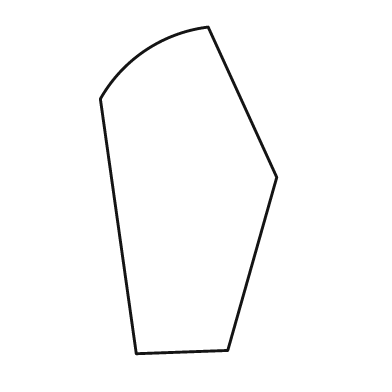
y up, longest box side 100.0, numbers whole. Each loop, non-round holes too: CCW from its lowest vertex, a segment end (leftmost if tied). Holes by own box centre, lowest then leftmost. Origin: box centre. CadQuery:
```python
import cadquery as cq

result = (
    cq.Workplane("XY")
    .moveTo(-16.0, -50.0)
    .lineTo(12.0, -49.0)
    .lineTo(27.0, 4.0)
    .lineTo(6.0, 50.0)
    .threePointArc((-13.0, 43.0), (-27.0, 28.0))
    .close()
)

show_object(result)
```